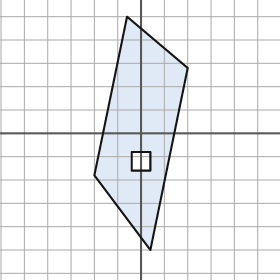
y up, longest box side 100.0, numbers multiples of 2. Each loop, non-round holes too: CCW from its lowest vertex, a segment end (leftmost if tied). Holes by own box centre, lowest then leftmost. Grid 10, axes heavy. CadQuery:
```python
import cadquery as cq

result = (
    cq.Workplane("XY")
    .moveTo(4.0, -50.0)
    .lineTo(20.0, 28.0)
    .lineTo(-6.0, 50.0)
    .lineTo(-20.0, -18.0)
    .close()
    .moveTo(-4.0, -16.0)
    .lineTo(4.0, -16.0)
    .lineTo(4.0, -8.0)
    .lineTo(-4.0, -8.0)
    .close()
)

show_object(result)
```